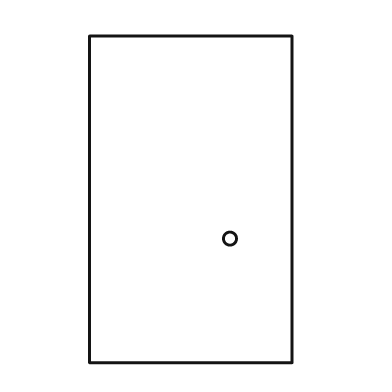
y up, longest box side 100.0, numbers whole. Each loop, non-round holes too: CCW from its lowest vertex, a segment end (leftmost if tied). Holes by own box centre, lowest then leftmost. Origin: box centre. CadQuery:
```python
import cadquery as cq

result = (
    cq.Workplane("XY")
    .moveTo(-31.0, -50.0)
    .lineTo(31.0, -50.0)
    .lineTo(31.0, 50.0)
    .lineTo(-31.0, 50.0)
    .close()
    .moveTo(12.0, -12.0)
    .circle(2.0)
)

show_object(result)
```